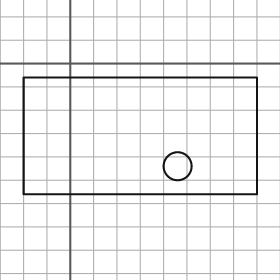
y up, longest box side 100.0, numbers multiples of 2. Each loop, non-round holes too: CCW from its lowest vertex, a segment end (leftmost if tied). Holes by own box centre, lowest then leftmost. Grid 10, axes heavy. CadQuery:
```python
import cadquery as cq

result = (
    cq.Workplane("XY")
    .moveTo(-20.0, -56.0)
    .lineTo(80.0, -56.0)
    .lineTo(80.0, -6.0)
    .lineTo(-20.0, -6.0)
    .close()
    .moveTo(46.0, -44.0)
    .circle(6.0)
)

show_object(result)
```